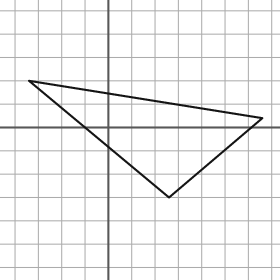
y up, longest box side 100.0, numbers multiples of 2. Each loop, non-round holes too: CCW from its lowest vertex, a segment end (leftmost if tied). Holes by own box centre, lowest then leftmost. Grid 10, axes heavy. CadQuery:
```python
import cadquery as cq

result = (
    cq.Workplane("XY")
    .moveTo(26.0, -30.0)
    .lineTo(66.0, 4.0)
    .lineTo(-34.0, 20.0)
    .close()
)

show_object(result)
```